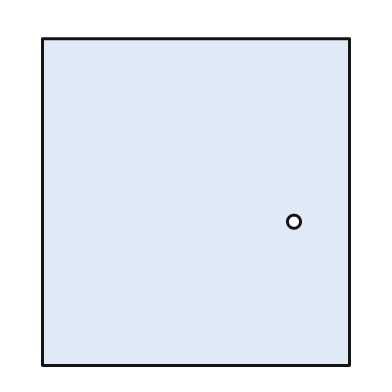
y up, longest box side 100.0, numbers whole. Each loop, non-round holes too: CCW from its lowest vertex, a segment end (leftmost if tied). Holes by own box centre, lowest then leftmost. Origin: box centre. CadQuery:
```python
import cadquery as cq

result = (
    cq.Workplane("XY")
    .moveTo(-47.0, -50.0)
    .lineTo(47.0, -50.0)
    .lineTo(47.0, 50.0)
    .lineTo(-47.0, 50.0)
    .close()
    .moveTo(30.0, -6.0)
    .circle(2.0)
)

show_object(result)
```